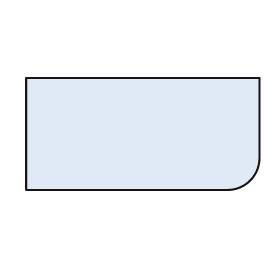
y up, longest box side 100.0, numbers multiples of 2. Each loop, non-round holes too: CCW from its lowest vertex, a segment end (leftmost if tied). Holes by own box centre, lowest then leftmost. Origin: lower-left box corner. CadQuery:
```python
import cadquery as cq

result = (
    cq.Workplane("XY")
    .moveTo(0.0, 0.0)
    .lineTo(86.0, 0.0)
    .threePointArc((96.0, 4.0), (100.0, 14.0))
    .lineTo(100.0, 48.0)
    .lineTo(0.0, 48.0)
    .close()
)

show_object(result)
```